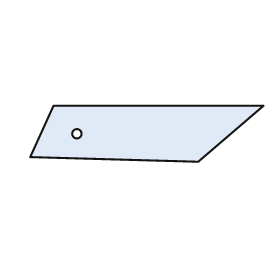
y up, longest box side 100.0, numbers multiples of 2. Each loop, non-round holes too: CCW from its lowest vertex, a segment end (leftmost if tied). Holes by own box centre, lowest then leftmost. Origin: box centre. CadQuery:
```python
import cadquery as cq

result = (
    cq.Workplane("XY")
    .moveTo(22.0, -12.0)
    .lineTo(50.0, 12.0)
    .lineTo(-40.0, 12.0)
    .lineTo(-50.0, -10.0)
    .close()
    .moveTo(-30.0, 0.0)
    .circle(2.0)
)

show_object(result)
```